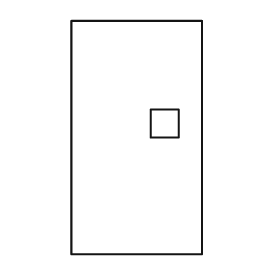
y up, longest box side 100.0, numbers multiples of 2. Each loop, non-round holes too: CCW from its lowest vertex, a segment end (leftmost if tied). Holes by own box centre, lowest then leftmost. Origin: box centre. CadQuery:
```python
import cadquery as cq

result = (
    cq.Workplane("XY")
    .moveTo(-28.0, -50.0)
    .lineTo(28.0, -50.0)
    .lineTo(28.0, 50.0)
    .lineTo(-28.0, 50.0)
    .close()
    .moveTo(6.0, 0.0)
    .lineTo(18.0, 0.0)
    .lineTo(18.0, 12.0)
    .lineTo(6.0, 12.0)
    .close()
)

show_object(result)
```